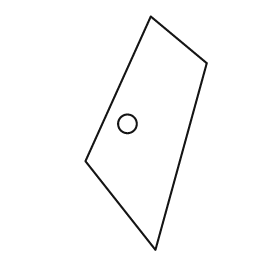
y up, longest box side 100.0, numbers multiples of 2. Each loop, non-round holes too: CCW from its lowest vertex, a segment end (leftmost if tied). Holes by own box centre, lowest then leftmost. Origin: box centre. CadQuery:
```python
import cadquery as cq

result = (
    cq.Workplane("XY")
    .moveTo(4.0, -50.0)
    .lineTo(26.0, 30.0)
    .lineTo(2.0, 50.0)
    .lineTo(-26.0, -12.0)
    .close()
    .moveTo(-8.0, 4.0)
    .circle(4.0)
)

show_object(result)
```